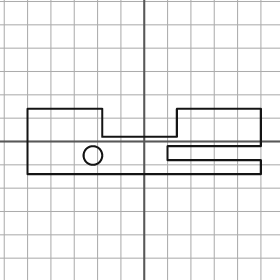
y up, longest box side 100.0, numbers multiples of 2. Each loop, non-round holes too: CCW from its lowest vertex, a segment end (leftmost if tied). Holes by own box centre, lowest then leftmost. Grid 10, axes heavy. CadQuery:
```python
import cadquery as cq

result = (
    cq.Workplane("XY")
    .moveTo(-50.0, -14.0)
    .lineTo(50.0, -14.0)
    .lineTo(50.0, -8.0)
    .lineTo(10.0, -8.0)
    .lineTo(10.0, -2.0)
    .lineTo(50.0, -2.0)
    .lineTo(50.0, 14.0)
    .lineTo(14.0, 14.0)
    .lineTo(14.0, 2.0)
    .lineTo(-18.0, 2.0)
    .lineTo(-18.0, 14.0)
    .lineTo(-50.0, 14.0)
    .close()
    .moveTo(-22.0, -6.0)
    .circle(4.0)
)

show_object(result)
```